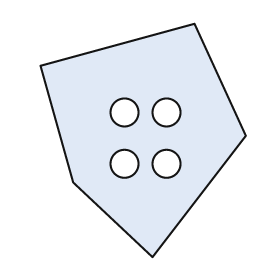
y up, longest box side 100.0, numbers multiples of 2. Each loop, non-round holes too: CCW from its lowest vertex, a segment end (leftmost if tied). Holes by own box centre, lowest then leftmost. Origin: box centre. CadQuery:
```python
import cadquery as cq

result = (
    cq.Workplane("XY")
    .moveTo(4.0, -50.0)
    .lineTo(44.0, 2.0)
    .lineTo(22.0, 50.0)
    .lineTo(-44.0, 32.0)
    .lineTo(-30.0, -18.0)
    .close()
    .moveTo(-8.0, -10.0)
    .circle(6.0)
    .moveTo(10.0, -10.0)
    .circle(6.0)
    .moveTo(-8.0, 12.0)
    .circle(6.0)
    .moveTo(10.0, 12.0)
    .circle(6.0)
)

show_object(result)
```